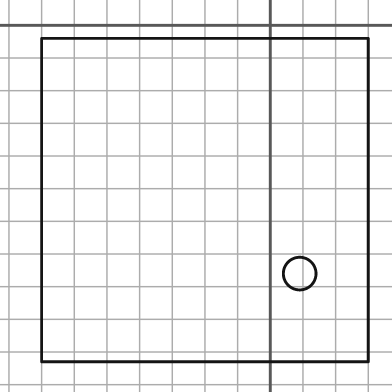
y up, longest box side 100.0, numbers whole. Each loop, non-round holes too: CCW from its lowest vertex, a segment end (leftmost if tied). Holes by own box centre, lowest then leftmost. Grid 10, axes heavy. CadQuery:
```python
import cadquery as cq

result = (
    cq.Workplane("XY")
    .moveTo(-70.0, -103.0)
    .lineTo(30.0, -103.0)
    .lineTo(30.0, -4.0)
    .lineTo(-70.0, -4.0)
    .close()
    .moveTo(9.0, -76.0)
    .circle(5.0)
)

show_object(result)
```